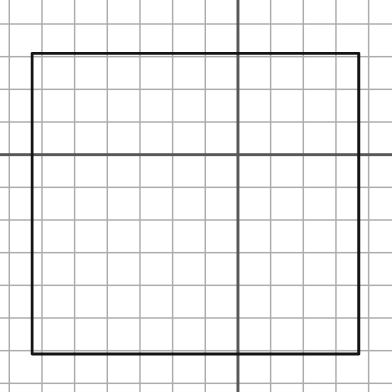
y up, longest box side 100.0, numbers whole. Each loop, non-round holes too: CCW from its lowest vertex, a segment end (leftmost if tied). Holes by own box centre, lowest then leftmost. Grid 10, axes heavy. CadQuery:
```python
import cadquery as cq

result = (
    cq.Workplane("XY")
    .moveTo(-63.0, -61.0)
    .lineTo(37.0, -61.0)
    .lineTo(37.0, 31.0)
    .lineTo(-63.0, 31.0)
    .close()
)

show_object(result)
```